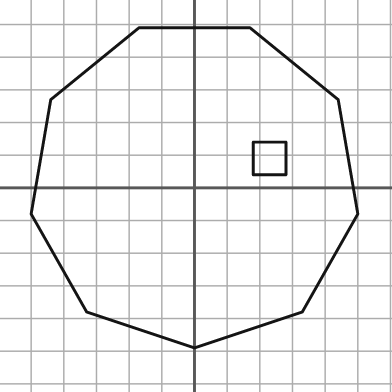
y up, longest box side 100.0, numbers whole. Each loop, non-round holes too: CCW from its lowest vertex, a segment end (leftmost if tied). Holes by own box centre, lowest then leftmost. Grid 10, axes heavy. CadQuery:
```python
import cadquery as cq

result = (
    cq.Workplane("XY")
    .moveTo(0.0, -49.0)
    .lineTo(33.0, -38.0)
    .lineTo(50.0, -8.0)
    .lineTo(44.0, 27.0)
    .lineTo(17.0, 49.0)
    .lineTo(-17.0, 49.0)
    .lineTo(-44.0, 27.0)
    .lineTo(-50.0, -8.0)
    .lineTo(-33.0, -38.0)
    .close()
    .moveTo(18.0, 4.0)
    .lineTo(28.0, 4.0)
    .lineTo(28.0, 14.0)
    .lineTo(18.0, 14.0)
    .close()
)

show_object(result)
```